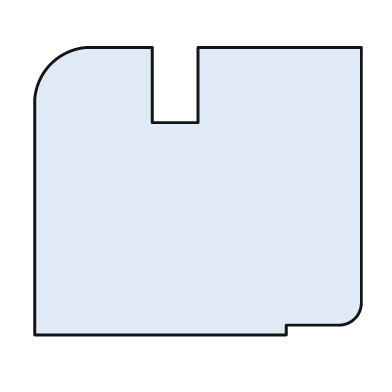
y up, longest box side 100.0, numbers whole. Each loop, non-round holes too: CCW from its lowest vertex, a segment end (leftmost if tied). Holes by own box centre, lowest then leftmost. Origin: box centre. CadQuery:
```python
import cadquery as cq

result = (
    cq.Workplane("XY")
    .moveTo(-50.0, -44.0)
    .lineTo(27.0, -44.0)
    .lineTo(27.0, -41.0)
    .lineTo(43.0, -41.0)
    .threePointArc((48.0, -39.0), (50.0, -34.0))
    .lineTo(50.0, 44.0)
    .lineTo(0.0, 44.0)
    .lineTo(0.0, 21.0)
    .lineTo(-14.0, 21.0)
    .lineTo(-14.0, 44.0)
    .lineTo(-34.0, 44.0)
    .threePointArc((-45.0, 39.0), (-50.0, 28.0))
    .close()
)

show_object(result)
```